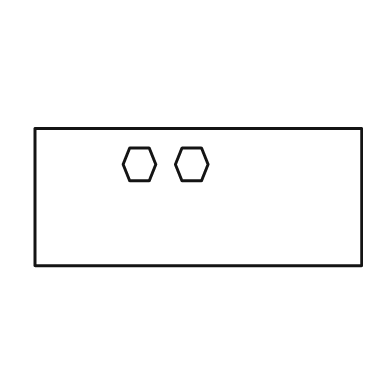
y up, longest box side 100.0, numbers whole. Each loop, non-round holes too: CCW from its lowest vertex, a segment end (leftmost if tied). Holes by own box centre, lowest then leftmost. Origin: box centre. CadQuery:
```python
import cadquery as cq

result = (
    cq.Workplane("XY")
    .moveTo(-50.0, -21.0)
    .lineTo(50.0, -21.0)
    .lineTo(50.0, 21.0)
    .lineTo(-50.0, 21.0)
    .close()
    .moveTo(-21.0, 5.0)
    .lineTo(-15.0, 5.0)
    .lineTo(-13.0, 10.0)
    .lineTo(-15.0, 15.0)
    .lineTo(-21.0, 15.0)
    .lineTo(-23.0, 10.0)
    .close()
    .moveTo(-5.0, 5.0)
    .lineTo(1.0, 5.0)
    .lineTo(3.0, 10.0)
    .lineTo(1.0, 15.0)
    .lineTo(-5.0, 15.0)
    .lineTo(-7.0, 10.0)
    .close()
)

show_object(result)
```